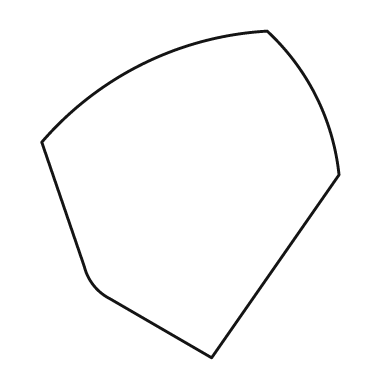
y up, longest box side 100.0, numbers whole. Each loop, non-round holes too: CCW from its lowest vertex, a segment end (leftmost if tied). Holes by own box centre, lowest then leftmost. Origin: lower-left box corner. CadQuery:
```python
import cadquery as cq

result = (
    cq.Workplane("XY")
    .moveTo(52.0, 0.0)
    .lineTo(91.0, 56.0)
    .threePointArc((84.0, 80.0), (69.0, 100.0))
    .threePointArc((31.0, 90.0), (0.0, 66.0))
    .lineTo(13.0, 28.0)
    .threePointArc((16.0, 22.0), (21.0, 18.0))
    .close()
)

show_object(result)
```